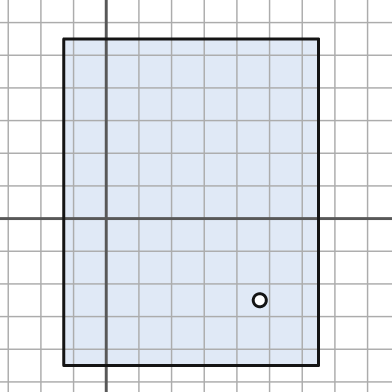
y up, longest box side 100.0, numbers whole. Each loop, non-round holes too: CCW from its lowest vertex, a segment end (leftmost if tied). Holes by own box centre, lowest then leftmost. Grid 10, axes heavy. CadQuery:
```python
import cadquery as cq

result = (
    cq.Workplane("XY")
    .moveTo(-13.0, -45.0)
    .lineTo(65.0, -45.0)
    .lineTo(65.0, 55.0)
    .lineTo(-13.0, 55.0)
    .close()
    .moveTo(47.0, -25.0)
    .circle(2.0)
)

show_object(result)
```